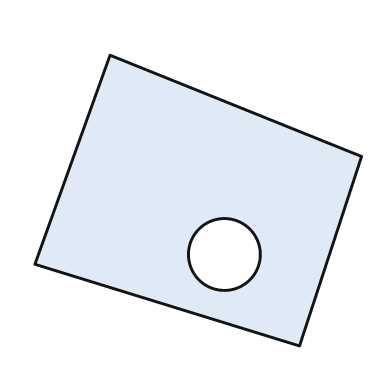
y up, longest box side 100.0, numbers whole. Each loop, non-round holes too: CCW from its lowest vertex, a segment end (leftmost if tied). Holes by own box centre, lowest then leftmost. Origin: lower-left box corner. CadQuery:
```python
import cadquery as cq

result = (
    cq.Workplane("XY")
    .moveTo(81.0, 0.0)
    .lineTo(100.0, 58.0)
    .lineTo(23.0, 89.0)
    .lineTo(0.0, 25.0)
    .close()
    .moveTo(58.0, 28.0)
    .circle(11.0)
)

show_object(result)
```